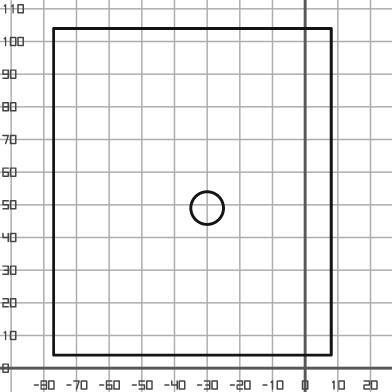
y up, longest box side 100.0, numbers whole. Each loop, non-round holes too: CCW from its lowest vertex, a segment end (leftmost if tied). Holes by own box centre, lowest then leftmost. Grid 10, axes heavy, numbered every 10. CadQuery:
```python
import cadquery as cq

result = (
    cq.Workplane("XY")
    .moveTo(-77.0, 4.0)
    .lineTo(8.0, 4.0)
    .lineTo(8.0, 104.0)
    .lineTo(-77.0, 104.0)
    .close()
    .moveTo(-30.0, 49.0)
    .circle(5.0)
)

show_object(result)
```